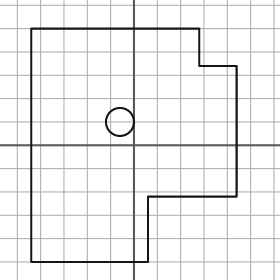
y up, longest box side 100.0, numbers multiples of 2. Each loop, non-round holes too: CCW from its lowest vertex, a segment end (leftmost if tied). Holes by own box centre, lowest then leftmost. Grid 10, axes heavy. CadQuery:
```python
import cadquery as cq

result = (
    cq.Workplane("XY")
    .moveTo(-44.0, -50.0)
    .lineTo(6.0, -50.0)
    .lineTo(6.0, -22.0)
    .lineTo(44.0, -22.0)
    .lineTo(44.0, 34.0)
    .lineTo(28.0, 34.0)
    .lineTo(28.0, 50.0)
    .lineTo(-44.0, 50.0)
    .close()
    .moveTo(-6.0, 10.0)
    .circle(6.0)
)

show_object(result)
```